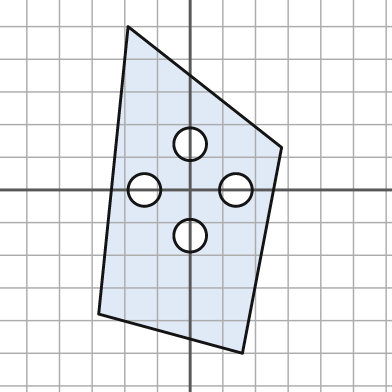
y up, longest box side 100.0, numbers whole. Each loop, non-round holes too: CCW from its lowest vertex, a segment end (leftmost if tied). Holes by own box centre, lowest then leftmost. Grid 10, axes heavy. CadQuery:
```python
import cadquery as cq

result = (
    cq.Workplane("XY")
    .moveTo(16.0, -50.0)
    .lineTo(28.0, 13.0)
    .lineTo(-19.0, 50.0)
    .lineTo(-28.0, -38.0)
    .close()
    .moveTo(0.0, -14.0)
    .circle(5.0)
    .moveTo(-14.0, 0.0)
    .circle(5.0)
    .moveTo(14.0, 0.0)
    .circle(5.0)
    .moveTo(0.0, 14.0)
    .circle(5.0)
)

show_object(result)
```